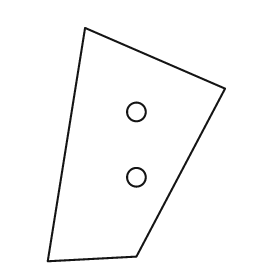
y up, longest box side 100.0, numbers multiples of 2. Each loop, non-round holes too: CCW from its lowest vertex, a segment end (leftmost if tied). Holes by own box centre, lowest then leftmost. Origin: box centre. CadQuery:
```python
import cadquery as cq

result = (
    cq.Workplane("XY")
    .moveTo(-38.0, -50.0)
    .lineTo(0.0, -48.0)
    .lineTo(38.0, 24.0)
    .lineTo(-22.0, 50.0)
    .close()
    .moveTo(0.0, -14.0)
    .circle(4.0)
    .moveTo(0.0, 14.0)
    .circle(4.0)
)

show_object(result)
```